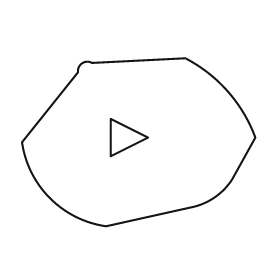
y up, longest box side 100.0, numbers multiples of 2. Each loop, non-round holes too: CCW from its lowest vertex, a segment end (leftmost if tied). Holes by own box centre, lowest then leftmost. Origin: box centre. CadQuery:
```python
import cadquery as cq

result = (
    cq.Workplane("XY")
    .moveTo(-14.0, -36.0)
    .lineTo(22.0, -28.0)
    .threePointArc((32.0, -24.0), (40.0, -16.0))
    .lineTo(50.0, 2.0)
    .threePointArc((38.0, 22.0), (20.0, 36.0))
    .lineTo(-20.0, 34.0)
    .threePointArc((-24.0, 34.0), (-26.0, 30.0))
    .lineTo(-50.0, 0.0)
    .threePointArc((-38.0, -24.0), (-14.0, -36.0))
    .close()
    .moveTo(-12.0, -6.0)
    .lineTo(4.0, 2.0)
    .lineTo(-12.0, 10.0)
    .close()
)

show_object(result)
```